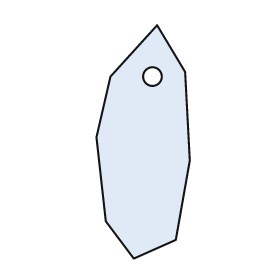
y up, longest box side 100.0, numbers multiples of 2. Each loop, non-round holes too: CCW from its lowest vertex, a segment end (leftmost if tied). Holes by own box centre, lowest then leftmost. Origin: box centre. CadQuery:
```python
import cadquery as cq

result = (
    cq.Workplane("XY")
    .moveTo(-4.0, -50.0)
    .lineTo(14.0, -42.0)
    .lineTo(20.0, -8.0)
    .lineTo(18.0, 30.0)
    .lineTo(6.0, 50.0)
    .lineTo(-14.0, 28.0)
    .lineTo(-20.0, 2.0)
    .lineTo(-16.0, -34.0)
    .close()
    .moveTo(4.0, 28.0)
    .circle(4.0)
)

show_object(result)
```